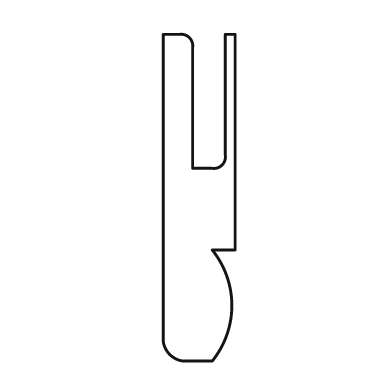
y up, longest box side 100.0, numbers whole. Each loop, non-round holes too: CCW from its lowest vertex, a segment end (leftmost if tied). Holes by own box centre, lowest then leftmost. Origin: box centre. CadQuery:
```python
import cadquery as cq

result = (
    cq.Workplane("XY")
    .moveTo(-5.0, -50.0)
    .lineTo(4.0, -50.0)
    .threePointArc((10.0, -33.0), (4.0, -16.0))
    .lineTo(11.0, -16.0)
    .lineTo(11.0, 50.0)
    .lineTo(8.0, 50.0)
    .lineTo(8.0, 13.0)
    .threePointArc((7.0, 10.0), (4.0, 9.0))
    .lineTo(-2.0, 9.0)
    .lineTo(-2.0, 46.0)
    .threePointArc((-3.0, 49.0), (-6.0, 50.0))
    .lineTo(-11.0, 50.0)
    .lineTo(-11.0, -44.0)
    .threePointArc((-9.0, -48.0), (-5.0, -50.0))
    .close()
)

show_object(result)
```